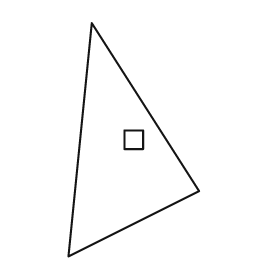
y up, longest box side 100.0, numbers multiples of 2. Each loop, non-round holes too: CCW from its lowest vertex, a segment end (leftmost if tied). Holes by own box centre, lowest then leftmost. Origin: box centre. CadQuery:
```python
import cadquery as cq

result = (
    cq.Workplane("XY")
    .moveTo(-28.0, -50.0)
    .lineTo(28.0, -22.0)
    .lineTo(-18.0, 50.0)
    .close()
    .moveTo(-4.0, -4.0)
    .lineTo(4.0, -4.0)
    .lineTo(4.0, 4.0)
    .lineTo(-4.0, 4.0)
    .close()
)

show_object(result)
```